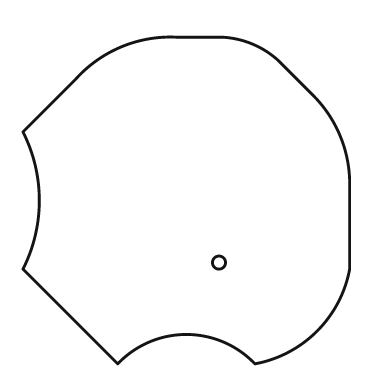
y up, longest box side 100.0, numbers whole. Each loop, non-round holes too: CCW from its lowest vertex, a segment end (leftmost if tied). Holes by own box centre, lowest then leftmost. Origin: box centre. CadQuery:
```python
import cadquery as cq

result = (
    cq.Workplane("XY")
    .moveTo(-21.0, -50.0)
    .threePointArc((0.0, -41.0), (21.0, -50.0))
    .threePointArc((40.0, -40.0), (50.0, -21.0))
    .lineTo(50.0, 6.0)
    .threePointArc((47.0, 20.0), (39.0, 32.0))
    .lineTo(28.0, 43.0)
    .threePointArc((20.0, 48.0), (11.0, 50.0))
    .lineTo(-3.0, 50.0)
    .threePointArc((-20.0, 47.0), (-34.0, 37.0))
    .lineTo(-50.0, 21.0)
    .threePointArc((-45.0, 0.0), (-50.0, -21.0))
    .close()
    .moveTo(10.0, -19.0)
    .circle(2.0)
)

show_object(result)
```